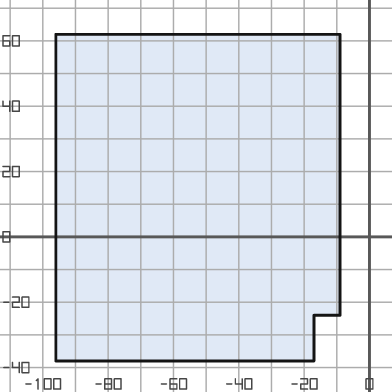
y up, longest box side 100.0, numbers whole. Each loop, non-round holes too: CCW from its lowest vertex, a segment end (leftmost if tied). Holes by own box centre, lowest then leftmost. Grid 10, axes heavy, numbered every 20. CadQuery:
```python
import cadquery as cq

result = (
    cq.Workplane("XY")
    .moveTo(-96.0, -38.0)
    .lineTo(-17.0, -38.0)
    .lineTo(-17.0, -24.0)
    .lineTo(-9.0, -24.0)
    .lineTo(-9.0, 62.0)
    .lineTo(-96.0, 62.0)
    .close()
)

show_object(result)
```